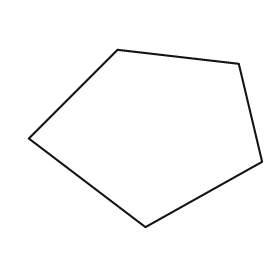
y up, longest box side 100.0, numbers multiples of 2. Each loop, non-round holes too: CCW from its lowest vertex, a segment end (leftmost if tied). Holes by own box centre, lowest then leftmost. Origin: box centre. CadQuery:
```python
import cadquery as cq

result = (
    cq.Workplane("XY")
    .moveTo(0.0, -38.0)
    .lineTo(50.0, -10.0)
    .lineTo(40.0, 32.0)
    .lineTo(-12.0, 38.0)
    .lineTo(-50.0, 0.0)
    .close()
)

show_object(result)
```